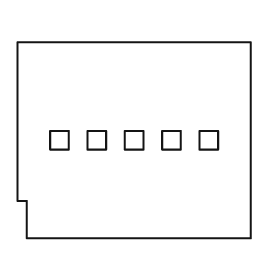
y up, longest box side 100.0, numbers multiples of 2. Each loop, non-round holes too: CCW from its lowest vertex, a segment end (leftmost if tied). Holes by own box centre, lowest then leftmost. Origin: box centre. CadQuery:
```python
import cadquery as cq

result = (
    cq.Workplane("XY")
    .moveTo(-46.0, -42.0)
    .lineTo(50.0, -42.0)
    .lineTo(50.0, 42.0)
    .lineTo(-50.0, 42.0)
    .lineTo(-50.0, -26.0)
    .lineTo(-46.0, -26.0)
    .close()
    .moveTo(-36.0, -4.0)
    .lineTo(-28.0, -4.0)
    .lineTo(-28.0, 4.0)
    .lineTo(-36.0, 4.0)
    .close()
    .moveTo(-20.0, -4.0)
    .lineTo(-12.0, -4.0)
    .lineTo(-12.0, 4.0)
    .lineTo(-20.0, 4.0)
    .close()
    .moveTo(-4.0, -4.0)
    .lineTo(4.0, -4.0)
    .lineTo(4.0, 4.0)
    .lineTo(-4.0, 4.0)
    .close()
    .moveTo(12.0, -4.0)
    .lineTo(20.0, -4.0)
    .lineTo(20.0, 4.0)
    .lineTo(12.0, 4.0)
    .close()
    .moveTo(28.0, -4.0)
    .lineTo(36.0, -4.0)
    .lineTo(36.0, 4.0)
    .lineTo(28.0, 4.0)
    .close()
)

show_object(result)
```